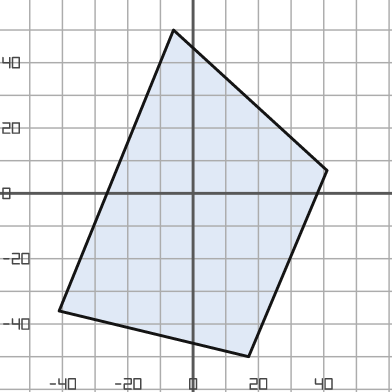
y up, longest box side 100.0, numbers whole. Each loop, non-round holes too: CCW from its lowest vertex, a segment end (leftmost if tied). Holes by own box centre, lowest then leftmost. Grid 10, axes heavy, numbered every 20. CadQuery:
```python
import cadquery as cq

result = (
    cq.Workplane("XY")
    .moveTo(17.0, -50.0)
    .lineTo(41.0, 7.0)
    .lineTo(-6.0, 50.0)
    .lineTo(-41.0, -36.0)
    .close()
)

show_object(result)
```